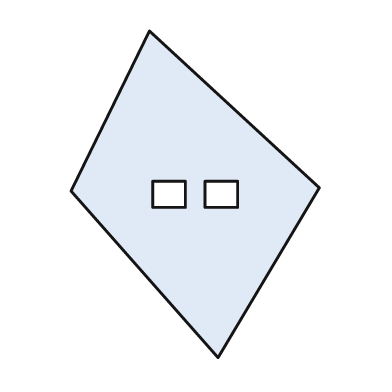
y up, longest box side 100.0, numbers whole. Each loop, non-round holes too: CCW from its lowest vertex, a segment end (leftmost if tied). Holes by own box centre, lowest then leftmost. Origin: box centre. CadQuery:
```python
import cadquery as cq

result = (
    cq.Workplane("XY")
    .moveTo(7.0, -50.0)
    .lineTo(38.0, 2.0)
    .lineTo(-14.0, 50.0)
    .lineTo(-38.0, 1.0)
    .close()
    .moveTo(-13.0, -4.0)
    .lineTo(-3.0, -4.0)
    .lineTo(-3.0, 4.0)
    .lineTo(-13.0, 4.0)
    .close()
    .moveTo(3.0, -4.0)
    .lineTo(13.0, -4.0)
    .lineTo(13.0, 4.0)
    .lineTo(3.0, 4.0)
    .close()
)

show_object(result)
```